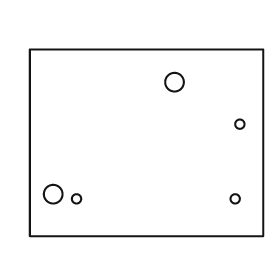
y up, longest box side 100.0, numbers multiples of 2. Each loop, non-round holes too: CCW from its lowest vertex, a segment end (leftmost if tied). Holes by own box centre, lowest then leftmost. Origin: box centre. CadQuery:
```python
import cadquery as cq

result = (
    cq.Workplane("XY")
    .moveTo(-50.0, -40.0)
    .lineTo(50.0, -40.0)
    .lineTo(50.0, 40.0)
    .lineTo(-50.0, 40.0)
    .close()
    .moveTo(-30.0, -24.0)
    .circle(2.0)
    .moveTo(38.0, -24.0)
    .circle(2.0)
    .moveTo(-40.0, -22.0)
    .circle(4.0)
    .moveTo(40.0, 8.0)
    .circle(2.0)
    .moveTo(12.0, 26.0)
    .circle(4.0)
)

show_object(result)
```